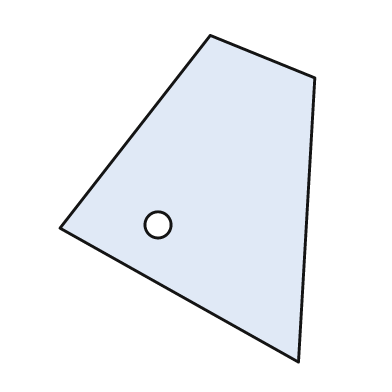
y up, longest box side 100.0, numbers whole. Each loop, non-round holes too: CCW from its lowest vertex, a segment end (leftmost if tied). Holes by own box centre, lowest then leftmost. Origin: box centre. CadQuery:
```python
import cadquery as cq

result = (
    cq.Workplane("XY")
    .moveTo(34.0, -50.0)
    .lineTo(39.0, 37.0)
    .lineTo(7.0, 50.0)
    .lineTo(-39.0, -9.0)
    .close()
    .moveTo(-9.0, -8.0)
    .circle(4.0)
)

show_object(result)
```